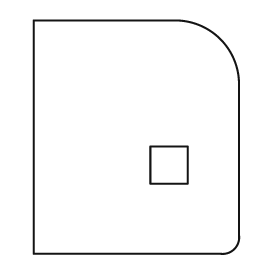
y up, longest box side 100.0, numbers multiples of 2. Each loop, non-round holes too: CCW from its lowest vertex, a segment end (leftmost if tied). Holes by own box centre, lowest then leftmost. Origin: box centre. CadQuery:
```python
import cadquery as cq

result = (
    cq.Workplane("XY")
    .moveTo(-44.0, -50.0)
    .lineTo(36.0, -50.0)
    .threePointArc((42.0, -48.0), (44.0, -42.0))
    .lineTo(44.0, 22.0)
    .threePointArc((36.0, 42.0), (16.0, 50.0))
    .lineTo(-44.0, 50.0)
    .close()
    .moveTo(6.0, -20.0)
    .lineTo(22.0, -20.0)
    .lineTo(22.0, -4.0)
    .lineTo(6.0, -4.0)
    .close()
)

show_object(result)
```